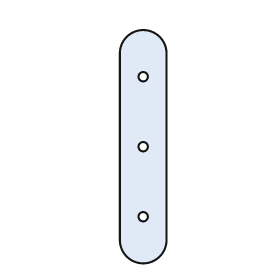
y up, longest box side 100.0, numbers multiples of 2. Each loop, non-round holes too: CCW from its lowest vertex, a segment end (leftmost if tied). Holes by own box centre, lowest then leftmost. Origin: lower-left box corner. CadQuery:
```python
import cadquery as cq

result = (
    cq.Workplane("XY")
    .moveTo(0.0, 10.0)
    .threePointArc((10.0, 0.0), (20.0, 10.0))
    .lineTo(20.0, 90.0)
    .threePointArc((10.0, 100.0), (0.0, 90.0))
    .close()
    .moveTo(10.0, 20.0)
    .circle(2.0)
    .moveTo(10.0, 50.0)
    .circle(2.0)
    .moveTo(10.0, 80.0)
    .circle(2.0)
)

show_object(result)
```